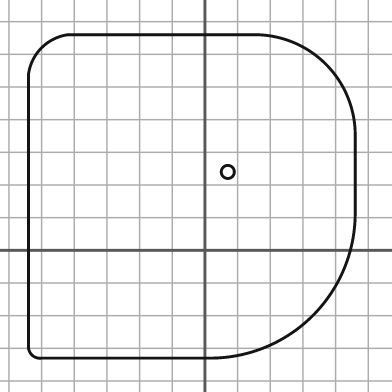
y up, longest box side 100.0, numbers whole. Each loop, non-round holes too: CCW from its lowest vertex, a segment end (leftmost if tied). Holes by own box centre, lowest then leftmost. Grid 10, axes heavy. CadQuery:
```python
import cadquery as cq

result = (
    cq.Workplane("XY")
    .moveTo(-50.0, -33.0)
    .lineTo(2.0, -33.0)
    .threePointArc((33.0, -20.0), (46.0, 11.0))
    .lineTo(46.0, 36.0)
    .threePointArc((37.0, 57.0), (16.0, 66.0))
    .lineTo(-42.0, 66.0)
    .threePointArc((-50.0, 62.0), (-54.0, 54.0))
    .lineTo(-54.0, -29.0)
    .threePointArc((-53.0, -32.0), (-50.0, -33.0))
    .close()
    .moveTo(7.0, 24.0)
    .circle(2.0)
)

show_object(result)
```